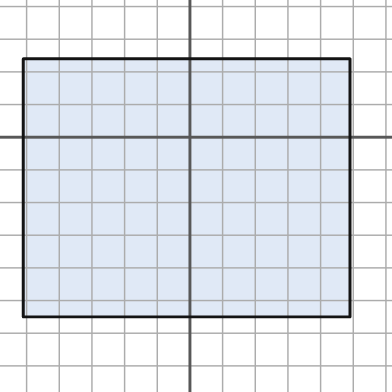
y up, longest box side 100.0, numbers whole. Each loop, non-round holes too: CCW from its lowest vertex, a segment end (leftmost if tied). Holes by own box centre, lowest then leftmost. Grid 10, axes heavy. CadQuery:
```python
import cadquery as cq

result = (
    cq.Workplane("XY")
    .moveTo(-51.0, -55.0)
    .lineTo(49.0, -55.0)
    .lineTo(49.0, 24.0)
    .lineTo(-51.0, 24.0)
    .close()
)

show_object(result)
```